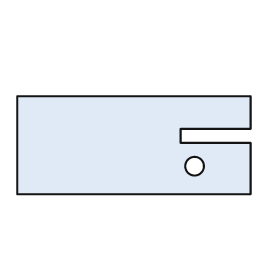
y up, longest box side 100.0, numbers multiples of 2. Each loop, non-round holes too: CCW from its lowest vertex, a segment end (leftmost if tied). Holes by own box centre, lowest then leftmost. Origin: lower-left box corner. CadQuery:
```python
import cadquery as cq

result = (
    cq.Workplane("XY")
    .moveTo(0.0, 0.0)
    .lineTo(100.0, 0.0)
    .lineTo(100.0, 22.0)
    .lineTo(70.0, 22.0)
    .lineTo(70.0, 28.0)
    .lineTo(100.0, 28.0)
    .lineTo(100.0, 42.0)
    .lineTo(0.0, 42.0)
    .close()
    .moveTo(76.0, 12.0)
    .circle(4.0)
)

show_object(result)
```